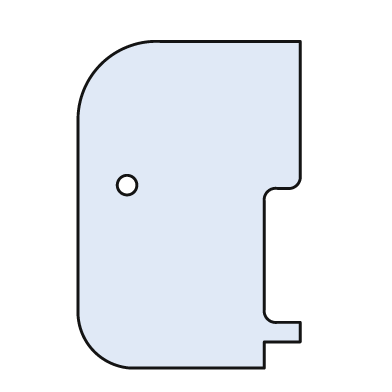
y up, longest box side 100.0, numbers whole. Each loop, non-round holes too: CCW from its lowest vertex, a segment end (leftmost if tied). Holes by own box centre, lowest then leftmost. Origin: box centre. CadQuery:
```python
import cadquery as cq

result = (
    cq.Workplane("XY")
    .moveTo(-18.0, -50.0)
    .lineTo(23.0, -50.0)
    .lineTo(23.0, -42.0)
    .lineTo(34.0, -42.0)
    .lineTo(34.0, -36.0)
    .lineTo(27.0, -36.0)
    .threePointArc((24.0, -35.0), (23.0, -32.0))
    .lineTo(23.0, 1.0)
    .threePointArc((24.0, 4.0), (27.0, 5.0))
    .lineTo(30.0, 5.0)
    .threePointArc((33.0, 6.0), (34.0, 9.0))
    .lineTo(34.0, 50.0)
    .lineTo(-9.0, 50.0)
    .threePointArc((-27.0, 43.0), (-34.0, 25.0))
    .lineTo(-34.0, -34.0)
    .threePointArc((-29.0, -45.0), (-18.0, -50.0))
    .close()
    .moveTo(-19.0, 6.0)
    .circle(3.0)
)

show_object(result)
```